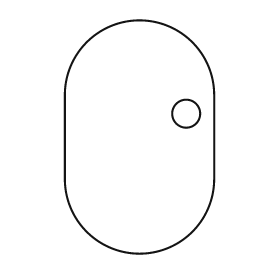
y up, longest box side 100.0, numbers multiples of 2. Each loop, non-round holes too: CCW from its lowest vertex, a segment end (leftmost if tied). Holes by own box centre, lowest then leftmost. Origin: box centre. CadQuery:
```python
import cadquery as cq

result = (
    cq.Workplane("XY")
    .moveTo(-32.0, -18.0)
    .threePointArc((0.0, -50.0), (32.0, -18.0))
    .lineTo(32.0, 18.0)
    .threePointArc((0.0, 50.0), (-32.0, 18.0))
    .close()
    .moveTo(20.0, 10.0)
    .circle(6.0)
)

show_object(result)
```